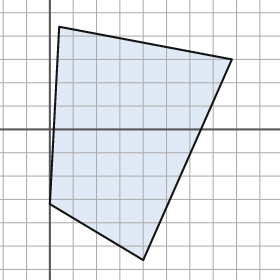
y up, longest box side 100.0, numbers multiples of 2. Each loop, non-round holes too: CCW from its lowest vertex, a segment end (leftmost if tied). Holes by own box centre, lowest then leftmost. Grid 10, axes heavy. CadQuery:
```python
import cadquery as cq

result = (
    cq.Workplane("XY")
    .moveTo(40.0, -56.0)
    .lineTo(78.0, 30.0)
    .lineTo(4.0, 44.0)
    .lineTo(0.0, -32.0)
    .close()
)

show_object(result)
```